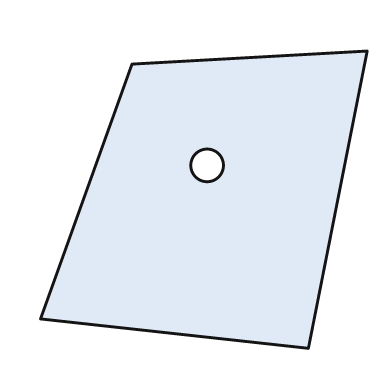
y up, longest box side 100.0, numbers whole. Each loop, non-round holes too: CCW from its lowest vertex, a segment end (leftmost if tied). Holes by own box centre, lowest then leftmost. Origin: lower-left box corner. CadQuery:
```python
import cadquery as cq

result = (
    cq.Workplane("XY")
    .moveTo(82.0, 0.0)
    .lineTo(100.0, 91.0)
    .lineTo(28.0, 87.0)
    .lineTo(0.0, 9.0)
    .close()
    .moveTo(51.0, 56.0)
    .circle(5.0)
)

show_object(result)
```